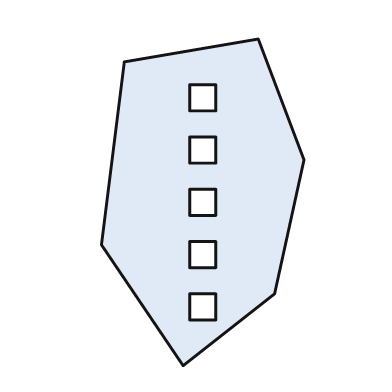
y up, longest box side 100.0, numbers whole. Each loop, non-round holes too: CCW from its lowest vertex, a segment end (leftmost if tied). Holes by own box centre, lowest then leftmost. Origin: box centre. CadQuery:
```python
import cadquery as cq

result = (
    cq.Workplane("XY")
    .moveTo(-6.0, -50.0)
    .lineTo(22.0, -28.0)
    .lineTo(31.0, 13.0)
    .lineTo(17.0, 50.0)
    .lineTo(-24.0, 43.0)
    .lineTo(-31.0, -13.0)
    .close()
    .moveTo(-4.0, -36.0)
    .lineTo(4.0, -36.0)
    .lineTo(4.0, -28.0)
    .lineTo(-4.0, -28.0)
    .close()
    .moveTo(-4.0, -20.0)
    .lineTo(4.0, -20.0)
    .lineTo(4.0, -12.0)
    .lineTo(-4.0, -12.0)
    .close()
    .moveTo(-4.0, -4.0)
    .lineTo(4.0, -4.0)
    .lineTo(4.0, 4.0)
    .lineTo(-4.0, 4.0)
    .close()
    .moveTo(-4.0, 12.0)
    .lineTo(4.0, 12.0)
    .lineTo(4.0, 20.0)
    .lineTo(-4.0, 20.0)
    .close()
    .moveTo(-4.0, 28.0)
    .lineTo(4.0, 28.0)
    .lineTo(4.0, 36.0)
    .lineTo(-4.0, 36.0)
    .close()
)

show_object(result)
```